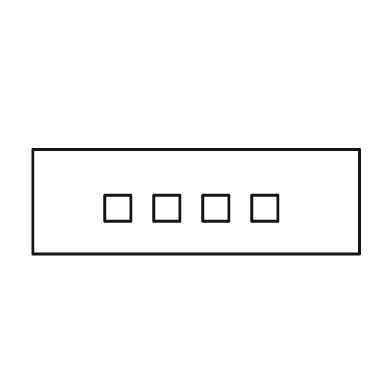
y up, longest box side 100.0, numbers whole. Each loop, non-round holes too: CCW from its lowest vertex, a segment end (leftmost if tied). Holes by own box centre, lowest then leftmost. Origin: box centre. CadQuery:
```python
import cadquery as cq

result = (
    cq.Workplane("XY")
    .moveTo(-50.0, -16.0)
    .lineTo(50.0, -16.0)
    .lineTo(50.0, 16.0)
    .lineTo(-50.0, 16.0)
    .close()
    .moveTo(-28.0, -6.0)
    .lineTo(-20.0, -6.0)
    .lineTo(-20.0, 2.0)
    .lineTo(-28.0, 2.0)
    .close()
    .moveTo(-13.0, -6.0)
    .lineTo(-5.0, -6.0)
    .lineTo(-5.0, 2.0)
    .lineTo(-13.0, 2.0)
    .close()
    .moveTo(2.0, -6.0)
    .lineTo(10.0, -6.0)
    .lineTo(10.0, 2.0)
    .lineTo(2.0, 2.0)
    .close()
    .moveTo(17.0, -6.0)
    .lineTo(25.0, -6.0)
    .lineTo(25.0, 2.0)
    .lineTo(17.0, 2.0)
    .close()
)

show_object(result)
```